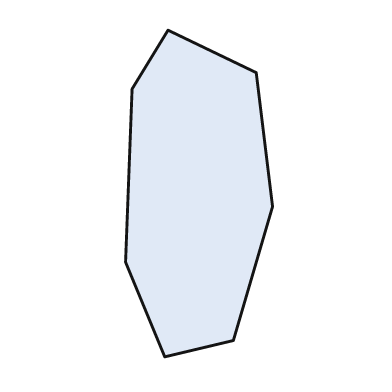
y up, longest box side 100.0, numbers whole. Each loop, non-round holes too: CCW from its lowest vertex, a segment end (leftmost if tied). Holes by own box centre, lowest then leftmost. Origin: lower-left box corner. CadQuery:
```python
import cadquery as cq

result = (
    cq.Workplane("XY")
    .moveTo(12.0, 0.0)
    .lineTo(33.0, 5.0)
    .lineTo(45.0, 46.0)
    .lineTo(40.0, 87.0)
    .lineTo(13.0, 100.0)
    .lineTo(2.0, 82.0)
    .lineTo(0.0, 29.0)
    .close()
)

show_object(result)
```